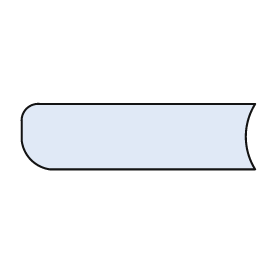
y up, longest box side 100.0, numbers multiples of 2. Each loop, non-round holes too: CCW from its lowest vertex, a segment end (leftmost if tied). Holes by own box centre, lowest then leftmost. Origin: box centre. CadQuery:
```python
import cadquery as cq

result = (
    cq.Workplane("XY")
    .moveTo(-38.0, -14.0)
    .lineTo(50.0, -14.0)
    .threePointArc((46.0, 0.0), (50.0, 14.0))
    .lineTo(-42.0, 14.0)
    .threePointArc((-48.0, 12.0), (-50.0, 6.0))
    .lineTo(-50.0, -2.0)
    .threePointArc((-46.0, -10.0), (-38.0, -14.0))
    .close()
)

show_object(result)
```